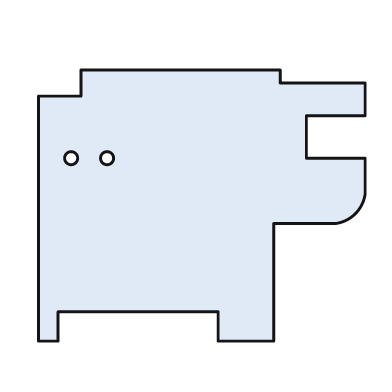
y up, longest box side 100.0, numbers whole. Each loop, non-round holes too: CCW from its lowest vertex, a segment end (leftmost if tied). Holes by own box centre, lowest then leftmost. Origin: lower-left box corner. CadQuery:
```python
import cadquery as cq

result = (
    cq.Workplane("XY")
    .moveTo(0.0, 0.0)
    .lineTo(6.0, 0.0)
    .lineTo(6.0, 9.0)
    .lineTo(55.0, 9.0)
    .lineTo(55.0, 0.0)
    .lineTo(72.0, 0.0)
    .lineTo(72.0, 36.0)
    .lineTo(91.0, 36.0)
    .threePointArc((97.0, 39.0), (100.0, 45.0))
    .lineTo(100.0, 56.0)
    .lineTo(82.0, 56.0)
    .lineTo(82.0, 69.0)
    .lineTo(100.0, 69.0)
    .lineTo(100.0, 79.0)
    .lineTo(74.0, 79.0)
    .lineTo(74.0, 83.0)
    .lineTo(13.0, 83.0)
    .lineTo(13.0, 75.0)
    .lineTo(0.0, 75.0)
    .close()
    .moveTo(10.0, 56.0)
    .circle(2.0)
    .moveTo(21.0, 56.0)
    .circle(2.0)
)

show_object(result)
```